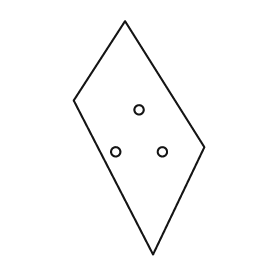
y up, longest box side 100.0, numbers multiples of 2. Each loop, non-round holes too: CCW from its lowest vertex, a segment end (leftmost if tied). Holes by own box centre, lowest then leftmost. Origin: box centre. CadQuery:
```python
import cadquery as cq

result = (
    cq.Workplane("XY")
    .moveTo(6.0, -50.0)
    .lineTo(28.0, -4.0)
    .lineTo(-6.0, 50.0)
    .lineTo(-28.0, 16.0)
    .close()
    .moveTo(-10.0, -6.0)
    .circle(2.0)
    .moveTo(10.0, -6.0)
    .circle(2.0)
    .moveTo(0.0, 12.0)
    .circle(2.0)
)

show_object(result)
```